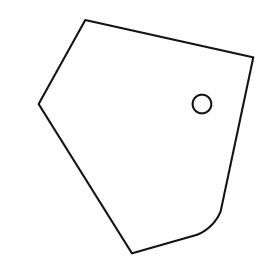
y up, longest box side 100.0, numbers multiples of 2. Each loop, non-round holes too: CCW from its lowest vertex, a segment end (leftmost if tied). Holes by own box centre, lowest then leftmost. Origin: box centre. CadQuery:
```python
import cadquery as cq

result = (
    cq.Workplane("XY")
    .moveTo(-6.0, -50.0)
    .lineTo(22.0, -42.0)
    .threePointArc((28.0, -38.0), (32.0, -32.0))
    .lineTo(46.0, 34.0)
    .lineTo(-26.0, 50.0)
    .lineTo(-46.0, 14.0)
    .close()
    .moveTo(24.0, 14.0)
    .circle(4.0)
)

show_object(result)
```